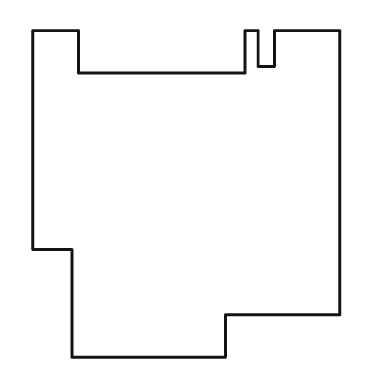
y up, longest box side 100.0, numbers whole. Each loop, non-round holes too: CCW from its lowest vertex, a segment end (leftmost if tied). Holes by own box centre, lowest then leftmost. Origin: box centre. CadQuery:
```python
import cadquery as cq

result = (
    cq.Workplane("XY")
    .moveTo(-35.0, -50.0)
    .lineTo(12.0, -50.0)
    .lineTo(12.0, -37.0)
    .lineTo(47.0, -37.0)
    .lineTo(47.0, 50.0)
    .lineTo(27.0, 50.0)
    .lineTo(27.0, 39.0)
    .lineTo(22.0, 39.0)
    .lineTo(22.0, 50.0)
    .lineTo(18.0, 50.0)
    .lineTo(18.0, 37.0)
    .lineTo(-33.0, 37.0)
    .lineTo(-33.0, 50.0)
    .lineTo(-47.0, 50.0)
    .lineTo(-47.0, -17.0)
    .lineTo(-35.0, -17.0)
    .close()
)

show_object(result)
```